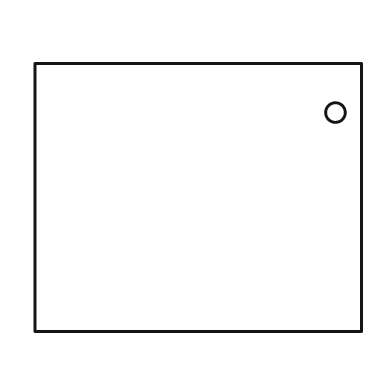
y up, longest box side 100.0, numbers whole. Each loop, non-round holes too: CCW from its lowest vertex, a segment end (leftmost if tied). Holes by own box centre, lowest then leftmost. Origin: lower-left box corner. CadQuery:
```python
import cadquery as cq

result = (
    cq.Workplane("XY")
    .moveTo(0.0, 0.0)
    .lineTo(100.0, 0.0)
    .lineTo(100.0, 82.0)
    .lineTo(0.0, 82.0)
    .close()
    .moveTo(92.0, 67.0)
    .circle(3.0)
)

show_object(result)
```